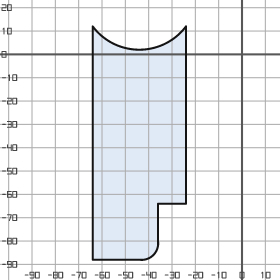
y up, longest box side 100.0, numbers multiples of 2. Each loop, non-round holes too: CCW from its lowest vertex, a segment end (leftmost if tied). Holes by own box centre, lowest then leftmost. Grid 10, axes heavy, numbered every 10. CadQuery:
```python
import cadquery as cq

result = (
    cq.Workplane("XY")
    .moveTo(-64.0, -88.0)
    .lineTo(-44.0, -88.0)
    .threePointArc((-38.0, -86.0), (-36.0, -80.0))
    .lineTo(-36.0, -64.0)
    .lineTo(-24.0, -64.0)
    .lineTo(-24.0, 12.0)
    .threePointArc((-44.0, 2.0), (-64.0, 12.0))
    .close()
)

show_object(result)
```